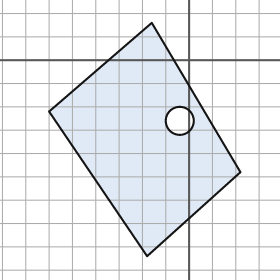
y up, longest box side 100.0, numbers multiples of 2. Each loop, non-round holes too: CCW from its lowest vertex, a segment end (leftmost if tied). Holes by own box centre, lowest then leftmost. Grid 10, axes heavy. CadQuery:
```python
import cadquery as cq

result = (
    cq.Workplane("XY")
    .moveTo(-18.0, -84.0)
    .lineTo(22.0, -48.0)
    .lineTo(-16.0, 16.0)
    .lineTo(-60.0, -22.0)
    .close()
    .moveTo(-4.0, -26.0)
    .circle(6.0)
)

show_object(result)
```